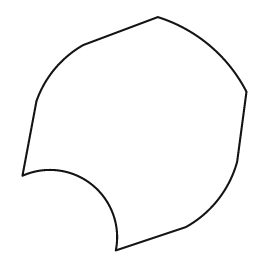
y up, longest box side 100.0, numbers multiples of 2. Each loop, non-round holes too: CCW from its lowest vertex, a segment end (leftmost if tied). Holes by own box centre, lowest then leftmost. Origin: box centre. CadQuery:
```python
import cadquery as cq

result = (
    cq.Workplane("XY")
    .moveTo(-8.0, -50.0)
    .lineTo(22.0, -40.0)
    .threePointArc((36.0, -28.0), (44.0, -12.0))
    .lineTo(48.0, 18.0)
    .threePointArc((32.0, 38.0), (10.0, 50.0))
    .lineTo(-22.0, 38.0)
    .threePointArc((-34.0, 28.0), (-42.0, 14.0))
    .lineTo(-48.0, -18.0)
    .threePointArc((-18.0, -22.0), (-8.0, -50.0))
    .close()
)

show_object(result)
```